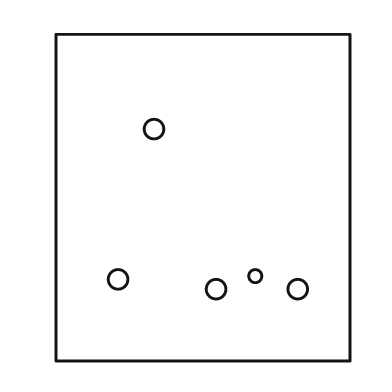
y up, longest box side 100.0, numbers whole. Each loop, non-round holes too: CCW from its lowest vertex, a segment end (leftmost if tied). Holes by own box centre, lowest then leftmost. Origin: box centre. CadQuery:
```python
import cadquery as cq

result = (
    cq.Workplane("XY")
    .moveTo(-45.0, -50.0)
    .lineTo(45.0, -50.0)
    .lineTo(45.0, 50.0)
    .lineTo(-45.0, 50.0)
    .close()
    .moveTo(4.0, -28.0)
    .circle(3.0)
    .moveTo(29.0, -28.0)
    .circle(3.0)
    .moveTo(-26.0, -25.0)
    .circle(3.0)
    .moveTo(16.0, -24.0)
    .circle(2.0)
    .moveTo(-15.0, 21.0)
    .circle(3.0)
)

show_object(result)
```